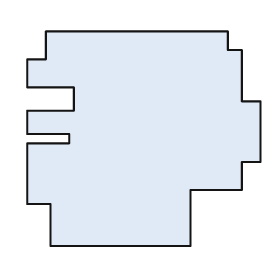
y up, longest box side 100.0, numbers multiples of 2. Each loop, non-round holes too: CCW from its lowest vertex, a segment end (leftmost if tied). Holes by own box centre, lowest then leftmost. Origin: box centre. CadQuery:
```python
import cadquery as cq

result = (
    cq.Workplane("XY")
    .moveTo(-40.0, -46.0)
    .lineTo(20.0, -46.0)
    .lineTo(20.0, -22.0)
    .lineTo(42.0, -22.0)
    .lineTo(42.0, -10.0)
    .lineTo(50.0, -10.0)
    .lineTo(50.0, 16.0)
    .lineTo(42.0, 16.0)
    .lineTo(42.0, 38.0)
    .lineTo(36.0, 38.0)
    .lineTo(36.0, 46.0)
    .lineTo(-42.0, 46.0)
    .lineTo(-42.0, 34.0)
    .lineTo(-50.0, 34.0)
    .lineTo(-50.0, 22.0)
    .lineTo(-30.0, 22.0)
    .lineTo(-30.0, 12.0)
    .lineTo(-50.0, 12.0)
    .lineTo(-50.0, 2.0)
    .lineTo(-32.0, 2.0)
    .lineTo(-32.0, -2.0)
    .lineTo(-50.0, -2.0)
    .lineTo(-50.0, -28.0)
    .lineTo(-40.0, -28.0)
    .close()
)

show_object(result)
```